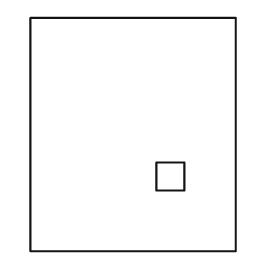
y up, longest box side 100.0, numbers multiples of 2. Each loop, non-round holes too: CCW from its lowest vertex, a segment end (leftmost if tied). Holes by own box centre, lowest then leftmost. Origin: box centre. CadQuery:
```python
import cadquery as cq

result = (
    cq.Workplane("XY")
    .moveTo(-44.0, -50.0)
    .lineTo(44.0, -50.0)
    .lineTo(44.0, 50.0)
    .lineTo(-44.0, 50.0)
    .close()
    .moveTo(10.0, -24.0)
    .lineTo(22.0, -24.0)
    .lineTo(22.0, -12.0)
    .lineTo(10.0, -12.0)
    .close()
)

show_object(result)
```